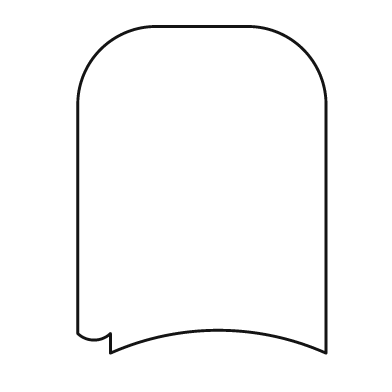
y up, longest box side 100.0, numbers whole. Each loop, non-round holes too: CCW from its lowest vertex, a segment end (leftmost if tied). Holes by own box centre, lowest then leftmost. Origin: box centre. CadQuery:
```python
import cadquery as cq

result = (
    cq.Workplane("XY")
    .moveTo(-28.0, -50.0)
    .threePointArc((5.0, -43.0), (38.0, -50.0))
    .lineTo(38.0, 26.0)
    .threePointArc((31.0, 43.0), (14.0, 50.0))
    .lineTo(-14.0, 50.0)
    .threePointArc((-31.0, 43.0), (-38.0, 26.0))
    .lineTo(-38.0, -44.0)
    .threePointArc((-33.0, -46.0), (-28.0, -44.0))
    .close()
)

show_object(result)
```